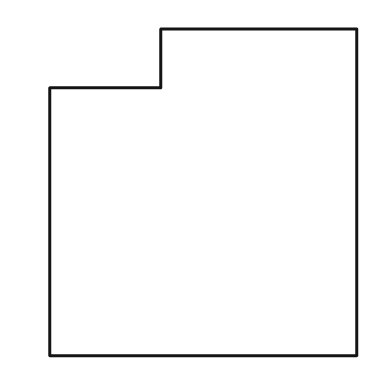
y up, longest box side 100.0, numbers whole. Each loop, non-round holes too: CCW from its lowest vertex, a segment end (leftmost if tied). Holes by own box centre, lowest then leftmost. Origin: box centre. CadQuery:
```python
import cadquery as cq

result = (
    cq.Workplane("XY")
    .moveTo(-47.0, -50.0)
    .lineTo(47.0, -50.0)
    .lineTo(47.0, 50.0)
    .lineTo(-13.0, 50.0)
    .lineTo(-13.0, 32.0)
    .lineTo(-47.0, 32.0)
    .close()
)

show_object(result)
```